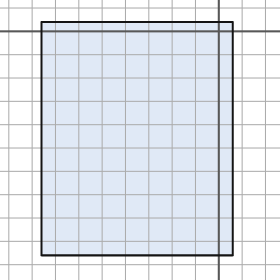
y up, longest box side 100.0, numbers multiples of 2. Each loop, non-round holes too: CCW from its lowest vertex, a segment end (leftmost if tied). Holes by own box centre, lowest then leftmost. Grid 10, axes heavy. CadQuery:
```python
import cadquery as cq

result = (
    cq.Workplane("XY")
    .moveTo(-76.0, -96.0)
    .lineTo(6.0, -96.0)
    .lineTo(6.0, 4.0)
    .lineTo(-76.0, 4.0)
    .close()
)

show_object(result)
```